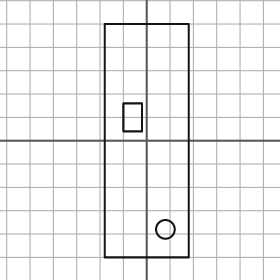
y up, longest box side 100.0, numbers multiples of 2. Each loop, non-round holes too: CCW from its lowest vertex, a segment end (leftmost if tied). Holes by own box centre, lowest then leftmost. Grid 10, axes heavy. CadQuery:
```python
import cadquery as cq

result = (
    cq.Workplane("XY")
    .moveTo(-18.0, -50.0)
    .lineTo(18.0, -50.0)
    .lineTo(18.0, 50.0)
    .lineTo(-18.0, 50.0)
    .close()
    .moveTo(8.0, -38.0)
    .circle(4.0)
    .moveTo(-10.0, 4.0)
    .lineTo(-2.0, 4.0)
    .lineTo(-2.0, 16.0)
    .lineTo(-10.0, 16.0)
    .close()
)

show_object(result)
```